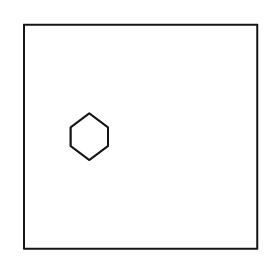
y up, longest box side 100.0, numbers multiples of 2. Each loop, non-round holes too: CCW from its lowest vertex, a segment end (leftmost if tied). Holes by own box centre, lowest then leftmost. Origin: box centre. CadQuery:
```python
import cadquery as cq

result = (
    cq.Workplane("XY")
    .moveTo(-50.0, -48.0)
    .lineTo(50.0, -48.0)
    .lineTo(50.0, 48.0)
    .lineTo(-50.0, 48.0)
    .close()
    .moveTo(-22.0, -10.0)
    .lineTo(-14.0, -4.0)
    .lineTo(-14.0, 4.0)
    .lineTo(-22.0, 10.0)
    .lineTo(-30.0, 4.0)
    .lineTo(-30.0, -4.0)
    .close()
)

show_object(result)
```